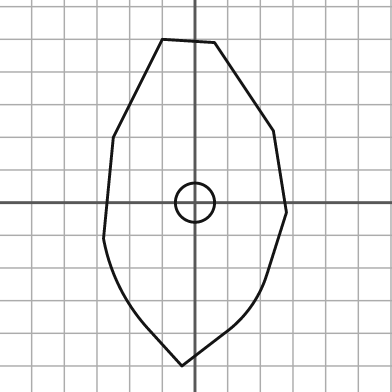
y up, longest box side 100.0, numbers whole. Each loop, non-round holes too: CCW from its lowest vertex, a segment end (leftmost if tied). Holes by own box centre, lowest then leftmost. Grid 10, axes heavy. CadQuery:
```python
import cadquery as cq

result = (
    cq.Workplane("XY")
    .moveTo(-4.0, -50.0)
    .lineTo(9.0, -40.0)
    .threePointArc((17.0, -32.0), (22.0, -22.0))
    .lineTo(28.0, -3.0)
    .lineTo(24.0, 22.0)
    .lineTo(6.0, 49.0)
    .lineTo(-10.0, 50.0)
    .lineTo(-25.0, 20.0)
    .lineTo(-28.0, -11.0)
    .threePointArc((-23.0, -26.0), (-14.0, -39.0))
    .close()
    .moveTo(0.0, 0.0)
    .circle(6.0)
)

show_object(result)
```